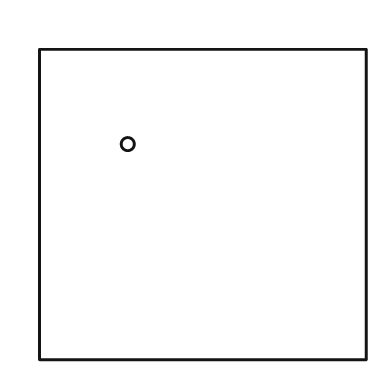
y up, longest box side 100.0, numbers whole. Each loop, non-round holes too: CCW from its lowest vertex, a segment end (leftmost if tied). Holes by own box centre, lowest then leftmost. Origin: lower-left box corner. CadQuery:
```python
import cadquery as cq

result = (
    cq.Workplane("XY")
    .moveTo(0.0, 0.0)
    .lineTo(100.0, 0.0)
    .lineTo(100.0, 95.0)
    .lineTo(0.0, 95.0)
    .close()
    .moveTo(27.0, 66.0)
    .circle(2.0)
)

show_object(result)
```